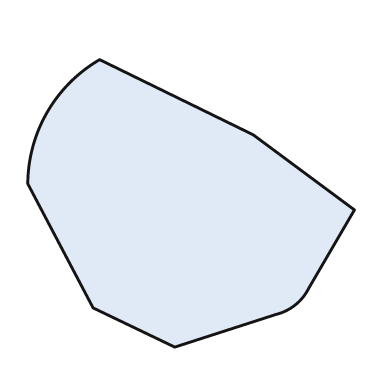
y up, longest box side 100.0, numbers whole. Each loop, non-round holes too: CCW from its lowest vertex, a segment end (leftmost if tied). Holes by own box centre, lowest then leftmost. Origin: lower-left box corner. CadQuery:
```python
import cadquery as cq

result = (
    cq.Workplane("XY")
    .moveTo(45.0, 0.0)
    .lineTo(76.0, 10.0)
    .threePointArc((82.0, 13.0), (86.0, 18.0))
    .lineTo(100.0, 42.0)
    .lineTo(69.0, 65.0)
    .lineTo(22.0, 88.0)
    .threePointArc((6.0, 72.0), (0.0, 50.0))
    .lineTo(20.0, 12.0)
    .close()
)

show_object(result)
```